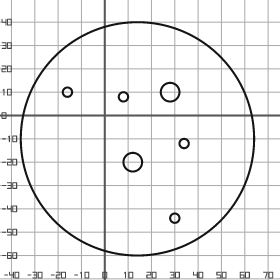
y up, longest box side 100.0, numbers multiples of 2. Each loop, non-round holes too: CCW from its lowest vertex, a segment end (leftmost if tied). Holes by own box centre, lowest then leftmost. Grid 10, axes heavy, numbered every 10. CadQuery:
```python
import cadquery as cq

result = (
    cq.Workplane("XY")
    .moveTo(14.0, -10.0)
    .circle(50.0)
    .moveTo(30.0, -44.0)
    .circle(2.0)
    .moveTo(12.0, -20.0)
    .circle(4.0)
    .moveTo(34.0, -12.0)
    .circle(2.0)
    .moveTo(8.0, 8.0)
    .circle(2.0)
    .moveTo(-16.0, 10.0)
    .circle(2.0)
    .moveTo(28.0, 10.0)
    .circle(4.0)
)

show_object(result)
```